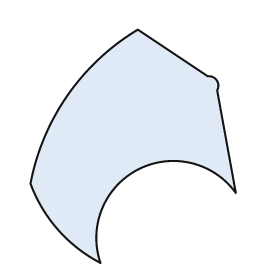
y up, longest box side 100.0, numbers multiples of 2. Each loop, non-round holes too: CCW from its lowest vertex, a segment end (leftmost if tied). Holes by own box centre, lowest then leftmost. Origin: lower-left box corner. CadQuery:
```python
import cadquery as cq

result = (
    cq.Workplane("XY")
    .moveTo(30.0, 0.0)
    .threePointArc((46.0, 40.0), (88.0, 30.0))
    .lineTo(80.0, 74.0)
    .threePointArc((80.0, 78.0), (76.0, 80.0))
    .lineTo(46.0, 100.0)
    .threePointArc((16.0, 72.0), (0.0, 34.0))
    .threePointArc((12.0, 14.0), (30.0, 0.0))
    .close()
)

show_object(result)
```